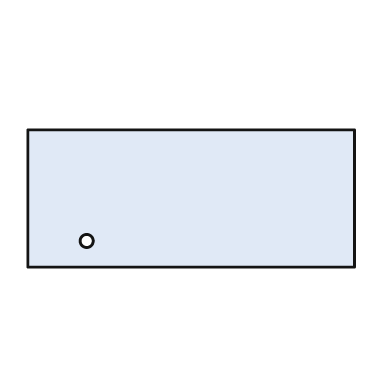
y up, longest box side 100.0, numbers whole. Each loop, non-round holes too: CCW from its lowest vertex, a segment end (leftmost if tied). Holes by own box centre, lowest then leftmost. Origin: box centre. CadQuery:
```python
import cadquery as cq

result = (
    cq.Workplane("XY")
    .moveTo(-50.0, -21.0)
    .lineTo(50.0, -21.0)
    .lineTo(50.0, 21.0)
    .lineTo(-50.0, 21.0)
    .close()
    .moveTo(-32.0, -13.0)
    .circle(2.0)
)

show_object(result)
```